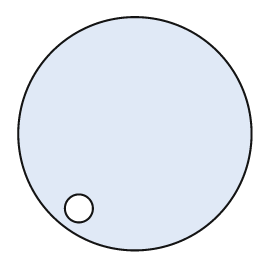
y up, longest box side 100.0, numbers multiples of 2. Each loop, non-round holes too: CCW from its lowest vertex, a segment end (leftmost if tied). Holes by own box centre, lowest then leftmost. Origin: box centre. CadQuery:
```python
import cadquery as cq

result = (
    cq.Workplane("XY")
    .moveTo(0.0, 0.0)
    .circle(50.0)
    .moveTo(-24.0, -32.0)
    .circle(6.0)
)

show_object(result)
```